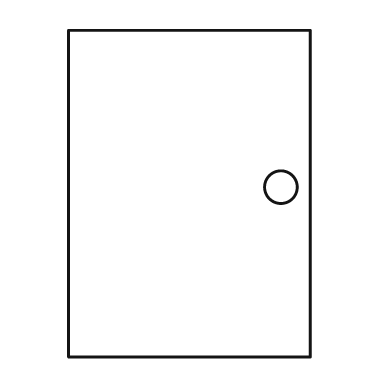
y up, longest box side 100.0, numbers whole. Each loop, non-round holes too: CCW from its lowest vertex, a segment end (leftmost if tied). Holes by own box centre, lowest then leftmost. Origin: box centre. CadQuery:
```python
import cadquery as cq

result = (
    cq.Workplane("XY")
    .moveTo(-37.0, -50.0)
    .lineTo(37.0, -50.0)
    .lineTo(37.0, 50.0)
    .lineTo(-37.0, 50.0)
    .close()
    .moveTo(28.0, 2.0)
    .circle(5.0)
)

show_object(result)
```